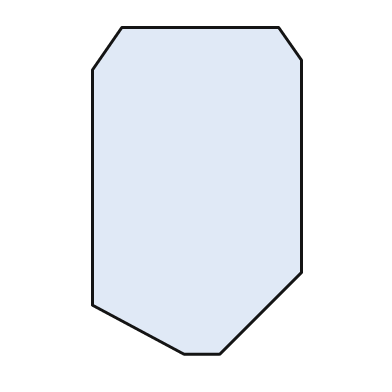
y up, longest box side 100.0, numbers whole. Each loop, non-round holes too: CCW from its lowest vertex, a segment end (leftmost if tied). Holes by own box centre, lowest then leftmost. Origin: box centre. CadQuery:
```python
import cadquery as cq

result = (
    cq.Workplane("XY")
    .moveTo(-4.0, -50.0)
    .lineTo(7.0, -50.0)
    .lineTo(32.0, -25.0)
    .lineTo(32.0, 40.0)
    .lineTo(25.0, 50.0)
    .lineTo(-23.0, 50.0)
    .lineTo(-32.0, 37.0)
    .lineTo(-32.0, -35.0)
    .close()
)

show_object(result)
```